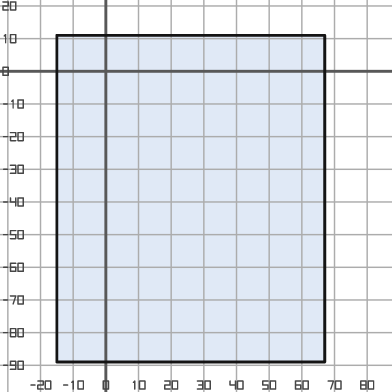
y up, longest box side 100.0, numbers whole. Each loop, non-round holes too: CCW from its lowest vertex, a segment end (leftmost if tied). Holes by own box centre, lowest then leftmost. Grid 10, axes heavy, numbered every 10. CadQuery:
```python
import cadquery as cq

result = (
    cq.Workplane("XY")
    .moveTo(-15.0, -89.0)
    .lineTo(67.0, -89.0)
    .lineTo(67.0, 11.0)
    .lineTo(-15.0, 11.0)
    .close()
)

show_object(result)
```